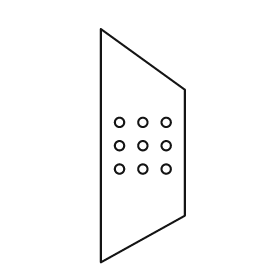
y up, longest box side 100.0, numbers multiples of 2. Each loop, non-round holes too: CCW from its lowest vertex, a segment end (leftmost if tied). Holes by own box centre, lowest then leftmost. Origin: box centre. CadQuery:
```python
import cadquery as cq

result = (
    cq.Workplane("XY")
    .moveTo(-18.0, -50.0)
    .lineTo(18.0, -30.0)
    .lineTo(18.0, 24.0)
    .lineTo(-18.0, 50.0)
    .close()
    .moveTo(-10.0, -10.0)
    .circle(2.0)
    .moveTo(0.0, -10.0)
    .circle(2.0)
    .moveTo(10.0, -10.0)
    .circle(2.0)
    .moveTo(-10.0, 0.0)
    .circle(2.0)
    .moveTo(0.0, 0.0)
    .circle(2.0)
    .moveTo(10.0, 0.0)
    .circle(2.0)
    .moveTo(-10.0, 10.0)
    .circle(2.0)
    .moveTo(0.0, 10.0)
    .circle(2.0)
    .moveTo(10.0, 10.0)
    .circle(2.0)
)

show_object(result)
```